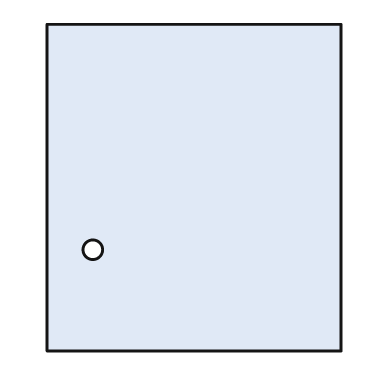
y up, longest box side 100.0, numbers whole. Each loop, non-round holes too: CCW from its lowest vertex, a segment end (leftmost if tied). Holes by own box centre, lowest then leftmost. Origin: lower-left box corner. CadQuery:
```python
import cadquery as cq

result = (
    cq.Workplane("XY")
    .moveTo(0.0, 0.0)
    .lineTo(90.0, 0.0)
    .lineTo(90.0, 100.0)
    .lineTo(0.0, 100.0)
    .close()
    .moveTo(14.0, 31.0)
    .circle(3.0)
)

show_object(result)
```